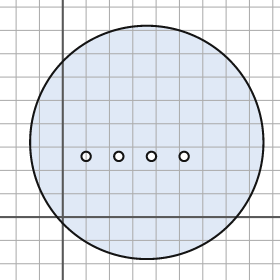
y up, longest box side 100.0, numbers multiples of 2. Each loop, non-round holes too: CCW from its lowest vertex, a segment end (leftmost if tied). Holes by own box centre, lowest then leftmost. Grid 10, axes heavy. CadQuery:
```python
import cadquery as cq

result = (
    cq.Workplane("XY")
    .moveTo(36.0, 32.0)
    .circle(50.0)
    .moveTo(10.0, 26.0)
    .circle(2.0)
    .moveTo(24.0, 26.0)
    .circle(2.0)
    .moveTo(38.0, 26.0)
    .circle(2.0)
    .moveTo(52.0, 26.0)
    .circle(2.0)
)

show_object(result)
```